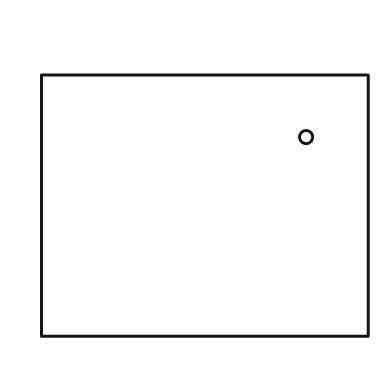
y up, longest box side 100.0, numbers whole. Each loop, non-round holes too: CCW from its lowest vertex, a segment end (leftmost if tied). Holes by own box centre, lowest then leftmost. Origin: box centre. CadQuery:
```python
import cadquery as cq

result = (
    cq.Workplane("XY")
    .moveTo(-50.0, -40.0)
    .lineTo(50.0, -40.0)
    .lineTo(50.0, 40.0)
    .lineTo(-50.0, 40.0)
    .close()
    .moveTo(31.0, 21.0)
    .circle(2.0)
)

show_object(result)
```